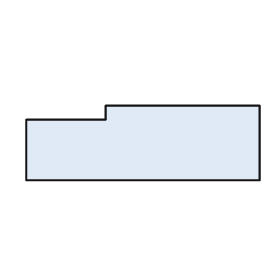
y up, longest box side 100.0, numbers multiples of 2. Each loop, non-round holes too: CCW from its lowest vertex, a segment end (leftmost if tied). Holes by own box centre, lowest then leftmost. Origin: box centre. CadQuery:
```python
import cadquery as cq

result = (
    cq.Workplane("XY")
    .moveTo(-50.0, -16.0)
    .lineTo(50.0, -16.0)
    .lineTo(50.0, 16.0)
    .lineTo(-16.0, 16.0)
    .lineTo(-16.0, 10.0)
    .lineTo(-50.0, 10.0)
    .close()
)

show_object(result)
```